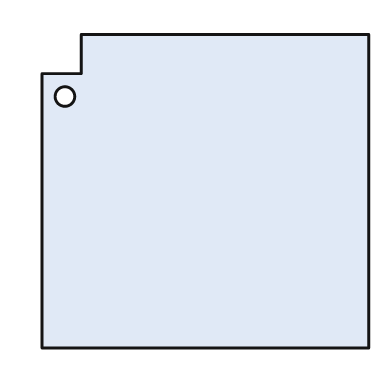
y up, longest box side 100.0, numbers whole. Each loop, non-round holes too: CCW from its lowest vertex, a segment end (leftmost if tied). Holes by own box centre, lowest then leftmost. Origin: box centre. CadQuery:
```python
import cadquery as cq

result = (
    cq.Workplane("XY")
    .moveTo(-50.0, -48.0)
    .lineTo(50.0, -48.0)
    .lineTo(50.0, 48.0)
    .lineTo(-38.0, 48.0)
    .lineTo(-38.0, 36.0)
    .lineTo(-50.0, 36.0)
    .close()
    .moveTo(-43.0, 29.0)
    .circle(3.0)
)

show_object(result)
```